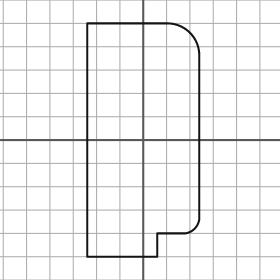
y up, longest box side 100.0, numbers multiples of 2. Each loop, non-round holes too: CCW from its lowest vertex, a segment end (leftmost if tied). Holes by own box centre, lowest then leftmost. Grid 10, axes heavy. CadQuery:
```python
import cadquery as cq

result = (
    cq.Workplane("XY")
    .moveTo(-24.0, -50.0)
    .lineTo(6.0, -50.0)
    .lineTo(6.0, -40.0)
    .lineTo(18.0, -40.0)
    .threePointArc((22.0, -38.0), (24.0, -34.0))
    .lineTo(24.0, 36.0)
    .threePointArc((20.0, 46.0), (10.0, 50.0))
    .lineTo(-24.0, 50.0)
    .close()
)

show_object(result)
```